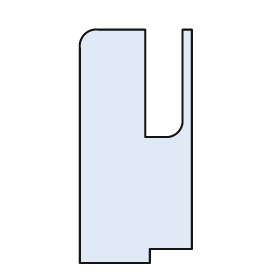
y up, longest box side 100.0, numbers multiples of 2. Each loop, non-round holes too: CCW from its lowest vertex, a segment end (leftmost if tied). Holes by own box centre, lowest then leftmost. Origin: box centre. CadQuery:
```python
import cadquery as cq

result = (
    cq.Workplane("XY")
    .moveTo(-24.0, -50.0)
    .lineTo(6.0, -50.0)
    .lineTo(6.0, -44.0)
    .lineTo(24.0, -44.0)
    .lineTo(24.0, 50.0)
    .lineTo(20.0, 50.0)
    .lineTo(20.0, 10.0)
    .threePointArc((18.0, 6.0), (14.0, 4.0))
    .lineTo(4.0, 4.0)
    .lineTo(4.0, 50.0)
    .lineTo(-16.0, 50.0)
    .threePointArc((-22.0, 48.0), (-24.0, 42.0))
    .close()
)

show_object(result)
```